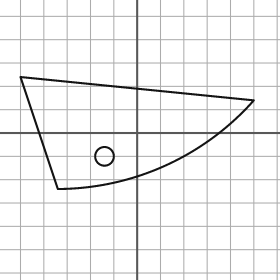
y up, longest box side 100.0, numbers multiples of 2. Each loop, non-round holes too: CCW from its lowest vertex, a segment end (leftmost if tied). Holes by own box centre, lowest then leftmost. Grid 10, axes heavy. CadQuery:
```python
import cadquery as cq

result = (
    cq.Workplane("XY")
    .moveTo(-34.0, -24.0)
    .threePointArc((12.0, -14.0), (50.0, 14.0))
    .lineTo(-50.0, 24.0)
    .close()
    .moveTo(-14.0, -10.0)
    .circle(4.0)
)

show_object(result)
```